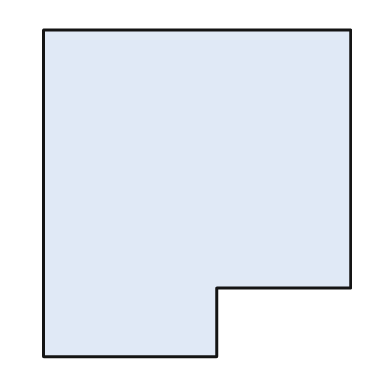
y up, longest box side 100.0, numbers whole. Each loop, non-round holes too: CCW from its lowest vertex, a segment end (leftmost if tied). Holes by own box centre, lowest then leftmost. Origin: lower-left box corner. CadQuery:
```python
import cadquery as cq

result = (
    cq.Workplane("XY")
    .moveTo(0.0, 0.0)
    .lineTo(53.0, 0.0)
    .lineTo(53.0, 21.0)
    .lineTo(94.0, 21.0)
    .lineTo(94.0, 100.0)
    .lineTo(0.0, 100.0)
    .close()
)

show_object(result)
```